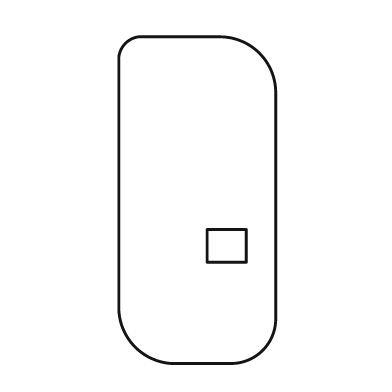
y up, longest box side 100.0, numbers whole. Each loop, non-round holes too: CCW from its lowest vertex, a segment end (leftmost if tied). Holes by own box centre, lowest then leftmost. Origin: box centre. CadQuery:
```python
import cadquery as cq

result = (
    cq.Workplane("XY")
    .moveTo(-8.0, -50.0)
    .lineTo(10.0, -50.0)
    .threePointArc((20.0, -46.0), (24.0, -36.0))
    .lineTo(24.0, 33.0)
    .threePointArc((19.0, 45.0), (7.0, 50.0))
    .lineTo(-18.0, 50.0)
    .threePointArc((-22.0, 48.0), (-24.0, 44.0))
    .lineTo(-24.0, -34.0)
    .threePointArc((-19.0, -45.0), (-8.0, -50.0))
    .close()
    .moveTo(3.0, -19.0)
    .lineTo(15.0, -19.0)
    .lineTo(15.0, -9.0)
    .lineTo(3.0, -9.0)
    .close()
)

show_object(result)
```